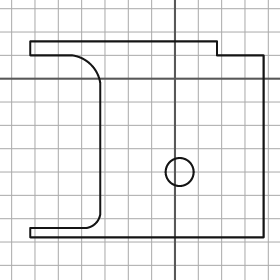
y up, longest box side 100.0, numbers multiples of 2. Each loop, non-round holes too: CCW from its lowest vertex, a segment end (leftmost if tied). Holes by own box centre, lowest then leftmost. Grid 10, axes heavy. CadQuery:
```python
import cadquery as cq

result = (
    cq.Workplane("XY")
    .moveTo(-62.0, -68.0)
    .lineTo(38.0, -68.0)
    .lineTo(38.0, 10.0)
    .lineTo(18.0, 10.0)
    .lineTo(18.0, 16.0)
    .lineTo(-62.0, 16.0)
    .lineTo(-62.0, 10.0)
    .lineTo(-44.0, 10.0)
    .threePointArc((-36.0, 6.0), (-32.0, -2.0))
    .lineTo(-32.0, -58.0)
    .threePointArc((-34.0, -62.0), (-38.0, -64.0))
    .lineTo(-62.0, -64.0)
    .close()
    .moveTo(2.0, -40.0)
    .circle(6.0)
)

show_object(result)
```